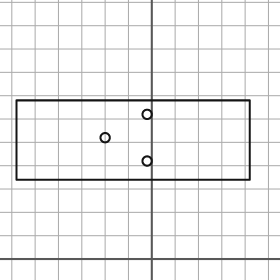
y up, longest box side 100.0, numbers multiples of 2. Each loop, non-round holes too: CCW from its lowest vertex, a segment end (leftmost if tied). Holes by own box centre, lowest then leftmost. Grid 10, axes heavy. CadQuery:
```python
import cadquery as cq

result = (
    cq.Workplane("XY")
    .moveTo(-58.0, 34.0)
    .lineTo(42.0, 34.0)
    .lineTo(42.0, 68.0)
    .lineTo(-58.0, 68.0)
    .close()
    .moveTo(-2.0, 42.0)
    .circle(2.0)
    .moveTo(-20.0, 52.0)
    .circle(2.0)
    .moveTo(-2.0, 62.0)
    .circle(2.0)
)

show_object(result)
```